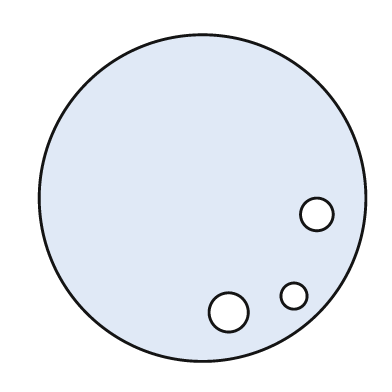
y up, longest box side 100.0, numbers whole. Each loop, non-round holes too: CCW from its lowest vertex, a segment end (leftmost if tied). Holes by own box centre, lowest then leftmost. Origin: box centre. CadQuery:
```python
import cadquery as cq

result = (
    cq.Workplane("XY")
    .moveTo(0.0, 0.0)
    .circle(50.0)
    .moveTo(8.0, -35.0)
    .circle(6.0)
    .moveTo(28.0, -30.0)
    .circle(4.0)
    .moveTo(35.0, -5.0)
    .circle(5.0)
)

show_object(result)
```